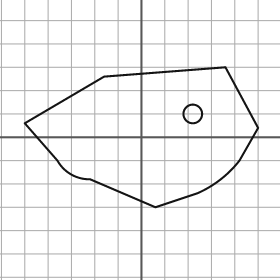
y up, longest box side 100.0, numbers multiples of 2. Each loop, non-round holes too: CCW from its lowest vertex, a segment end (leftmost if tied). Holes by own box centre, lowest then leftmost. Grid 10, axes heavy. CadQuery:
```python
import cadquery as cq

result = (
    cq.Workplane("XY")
    .moveTo(6.0, -30.0)
    .lineTo(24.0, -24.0)
    .threePointArc((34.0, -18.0), (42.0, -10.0))
    .lineTo(50.0, 4.0)
    .lineTo(36.0, 30.0)
    .lineTo(-16.0, 26.0)
    .lineTo(-50.0, 6.0)
    .lineTo(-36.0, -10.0)
    .threePointArc((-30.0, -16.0), (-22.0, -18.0))
    .close()
    .moveTo(22.0, 10.0)
    .circle(4.0)
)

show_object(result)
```